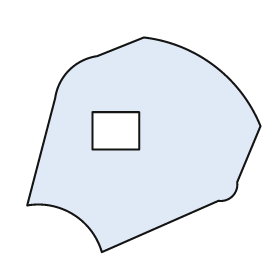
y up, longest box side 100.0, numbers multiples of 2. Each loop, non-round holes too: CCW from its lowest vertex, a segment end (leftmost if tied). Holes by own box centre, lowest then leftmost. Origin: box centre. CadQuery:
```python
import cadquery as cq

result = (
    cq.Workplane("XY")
    .moveTo(-18.0, -46.0)
    .lineTo(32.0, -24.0)
    .threePointArc((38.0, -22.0), (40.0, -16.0))
    .lineTo(50.0, 8.0)
    .threePointArc((30.0, 34.0), (0.0, 46.0))
    .lineTo(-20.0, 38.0)
    .threePointArc((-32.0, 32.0), (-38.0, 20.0))
    .lineTo(-50.0, -26.0)
    .threePointArc((-30.0, -30.0), (-18.0, -46.0))
    .close()
    .moveTo(-22.0, -2.0)
    .lineTo(-2.0, -2.0)
    .lineTo(-2.0, 14.0)
    .lineTo(-22.0, 14.0)
    .close()
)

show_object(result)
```